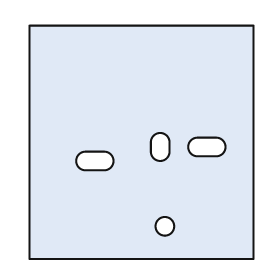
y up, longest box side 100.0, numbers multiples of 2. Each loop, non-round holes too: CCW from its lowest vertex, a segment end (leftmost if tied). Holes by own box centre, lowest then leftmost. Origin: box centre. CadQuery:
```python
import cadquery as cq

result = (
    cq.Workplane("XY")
    .moveTo(-48.0, -50.0)
    .lineTo(48.0, -50.0)
    .lineTo(48.0, 50.0)
    .lineTo(-48.0, 50.0)
    .close()
    .moveTo(10.0, -36.0)
    .circle(4.0)
    .moveTo(-24.0, -12.0)
    .lineTo(-16.0, -12.0)
    .threePointArc((-12.0, -8.0), (-16.0, -4.0))
    .lineTo(-24.0, -4.0)
    .threePointArc((-28.0, -8.0), (-24.0, -12.0))
    .close()
    .moveTo(4.0, -4.0)
    .threePointArc((8.0, -8.0), (12.0, -4.0))
    .lineTo(12.0, 0.0)
    .threePointArc((8.0, 4.0), (4.0, 0.0))
    .close()
    .moveTo(24.0, -6.0)
    .lineTo(32.0, -6.0)
    .threePointArc((36.0, -2.0), (32.0, 2.0))
    .lineTo(24.0, 2.0)
    .threePointArc((20.0, -2.0), (24.0, -6.0))
    .close()
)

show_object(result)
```